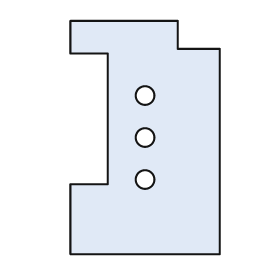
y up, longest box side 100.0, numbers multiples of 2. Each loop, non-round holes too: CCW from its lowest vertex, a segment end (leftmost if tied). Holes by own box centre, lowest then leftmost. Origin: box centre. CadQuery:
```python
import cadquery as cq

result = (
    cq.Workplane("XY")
    .moveTo(-32.0, -50.0)
    .lineTo(32.0, -50.0)
    .lineTo(32.0, 38.0)
    .lineTo(14.0, 38.0)
    .lineTo(14.0, 50.0)
    .lineTo(-32.0, 50.0)
    .lineTo(-32.0, 36.0)
    .lineTo(-16.0, 36.0)
    .lineTo(-16.0, -20.0)
    .lineTo(-32.0, -20.0)
    .close()
    .moveTo(0.0, -18.0)
    .circle(4.0)
    .moveTo(0.0, 0.0)
    .circle(4.0)
    .moveTo(0.0, 18.0)
    .circle(4.0)
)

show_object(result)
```